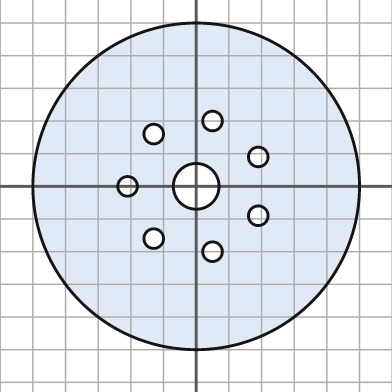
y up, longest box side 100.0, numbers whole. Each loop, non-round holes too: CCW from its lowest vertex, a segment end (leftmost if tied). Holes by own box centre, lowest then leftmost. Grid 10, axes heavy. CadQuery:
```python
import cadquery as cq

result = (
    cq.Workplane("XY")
    .moveTo(0.0, 0.0)
    .circle(50.0)
    .moveTo(5.0, -20.0)
    .circle(3.0)
    .moveTo(-13.0, -16.0)
    .circle(3.0)
    .moveTo(19.0, -9.0)
    .circle(3.0)
    .moveTo(-21.0, 0.0)
    .circle(3.0)
    .moveTo(0.0, 0.0)
    .circle(7.0)
    .moveTo(19.0, 9.0)
    .circle(3.0)
    .moveTo(-13.0, 16.0)
    .circle(3.0)
    .moveTo(5.0, 20.0)
    .circle(3.0)
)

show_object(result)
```